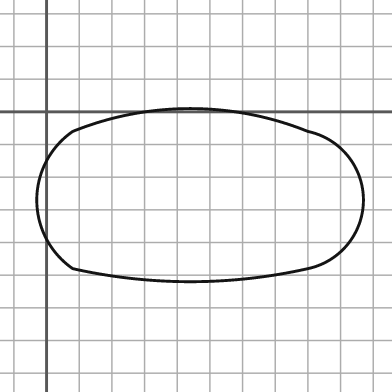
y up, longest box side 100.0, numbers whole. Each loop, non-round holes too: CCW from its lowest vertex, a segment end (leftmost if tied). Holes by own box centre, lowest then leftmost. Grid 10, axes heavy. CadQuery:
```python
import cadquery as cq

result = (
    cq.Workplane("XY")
    .moveTo(8.0, -48.0)
    .threePointArc((44.0, -52.0), (80.0, -48.0))
    .threePointArc((97.0, -27.0), (80.0, -6.0))
    .threePointArc((44.0, 1.0), (8.0, -6.0))
    .threePointArc((-3.0, -27.0), (8.0, -48.0))
    .close()
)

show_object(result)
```